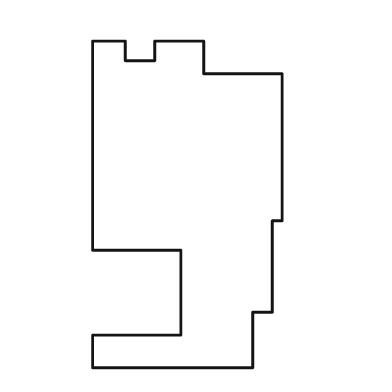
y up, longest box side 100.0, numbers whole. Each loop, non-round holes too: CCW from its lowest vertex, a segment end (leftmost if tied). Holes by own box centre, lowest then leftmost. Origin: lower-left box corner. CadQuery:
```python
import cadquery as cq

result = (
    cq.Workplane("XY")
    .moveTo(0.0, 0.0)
    .lineTo(49.0, 0.0)
    .lineTo(49.0, 17.0)
    .lineTo(55.0, 17.0)
    .lineTo(55.0, 45.0)
    .lineTo(58.0, 45.0)
    .lineTo(58.0, 90.0)
    .lineTo(34.0, 90.0)
    .lineTo(34.0, 100.0)
    .lineTo(19.0, 100.0)
    .lineTo(19.0, 94.0)
    .lineTo(10.0, 94.0)
    .lineTo(10.0, 100.0)
    .lineTo(0.0, 100.0)
    .lineTo(0.0, 36.0)
    .lineTo(27.0, 36.0)
    .lineTo(27.0, 10.0)
    .lineTo(0.0, 10.0)
    .close()
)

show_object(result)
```